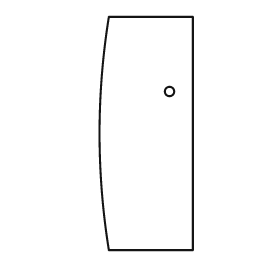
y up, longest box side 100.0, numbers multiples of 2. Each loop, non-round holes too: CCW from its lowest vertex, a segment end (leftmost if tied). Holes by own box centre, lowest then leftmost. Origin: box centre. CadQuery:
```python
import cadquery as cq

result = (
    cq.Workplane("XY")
    .moveTo(-16.0, -50.0)
    .lineTo(20.0, -50.0)
    .lineTo(20.0, 50.0)
    .lineTo(-16.0, 50.0)
    .threePointArc((-20.0, 0.0), (-16.0, -50.0))
    .close()
    .moveTo(10.0, 18.0)
    .circle(2.0)
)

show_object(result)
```